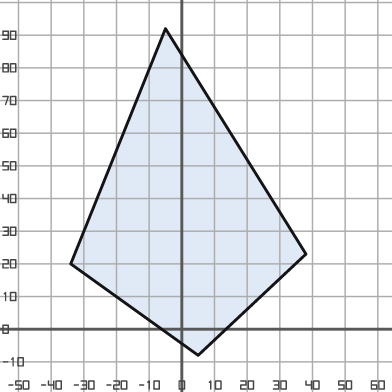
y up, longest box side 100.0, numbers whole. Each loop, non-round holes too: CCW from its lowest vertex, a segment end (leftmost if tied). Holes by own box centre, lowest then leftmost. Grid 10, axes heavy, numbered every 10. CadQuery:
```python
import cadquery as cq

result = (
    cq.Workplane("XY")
    .moveTo(5.0, -8.0)
    .lineTo(38.0, 23.0)
    .lineTo(-5.0, 92.0)
    .lineTo(-34.0, 20.0)
    .close()
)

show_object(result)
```